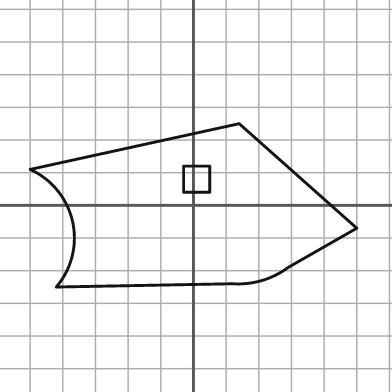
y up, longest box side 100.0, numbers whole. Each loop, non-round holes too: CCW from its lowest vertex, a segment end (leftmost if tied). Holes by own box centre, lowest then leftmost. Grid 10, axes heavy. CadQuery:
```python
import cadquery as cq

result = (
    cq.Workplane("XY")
    .moveTo(-42.0, -25.0)
    .lineTo(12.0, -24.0)
    .threePointArc((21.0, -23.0), (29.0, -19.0))
    .lineTo(50.0, -7.0)
    .lineTo(14.0, 25.0)
    .lineTo(-50.0, 11.0)
    .threePointArc((-37.0, -5.0), (-42.0, -25.0))
    .close()
    .moveTo(-3.0, 4.0)
    .lineTo(5.0, 4.0)
    .lineTo(5.0, 12.0)
    .lineTo(-3.0, 12.0)
    .close()
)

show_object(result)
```